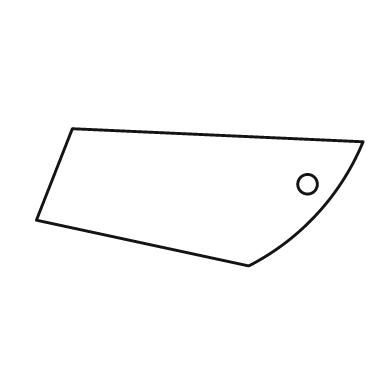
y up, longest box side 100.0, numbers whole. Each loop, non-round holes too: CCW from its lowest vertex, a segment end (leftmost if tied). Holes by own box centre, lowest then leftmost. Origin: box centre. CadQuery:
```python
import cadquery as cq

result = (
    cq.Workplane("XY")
    .moveTo(15.0, -21.0)
    .threePointArc((36.0, -5.0), (50.0, 17.0))
    .lineTo(-39.0, 21.0)
    .lineTo(-50.0, -7.0)
    .close()
    .moveTo(33.0, 4.0)
    .circle(3.0)
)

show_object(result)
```